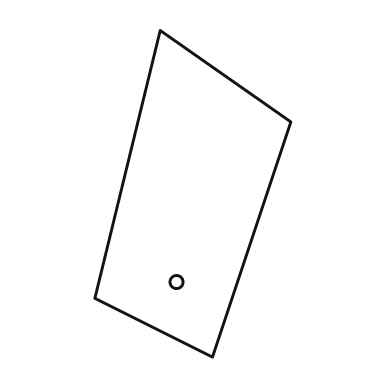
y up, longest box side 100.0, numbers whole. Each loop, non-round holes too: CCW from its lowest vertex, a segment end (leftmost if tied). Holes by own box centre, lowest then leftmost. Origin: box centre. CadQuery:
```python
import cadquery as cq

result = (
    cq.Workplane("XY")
    .moveTo(6.0, -50.0)
    .lineTo(30.0, 22.0)
    .lineTo(-10.0, 50.0)
    .lineTo(-30.0, -32.0)
    .close()
    .moveTo(-5.0, -27.0)
    .circle(2.0)
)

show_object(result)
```